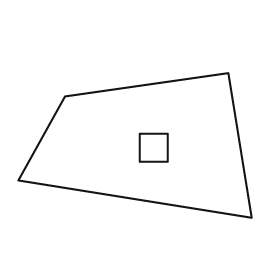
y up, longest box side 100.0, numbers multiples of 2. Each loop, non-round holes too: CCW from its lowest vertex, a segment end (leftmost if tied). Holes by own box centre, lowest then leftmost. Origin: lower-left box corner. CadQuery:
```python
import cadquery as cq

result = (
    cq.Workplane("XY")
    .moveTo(100.0, 0.0)
    .lineTo(90.0, 62.0)
    .lineTo(20.0, 52.0)
    .lineTo(0.0, 16.0)
    .close()
    .moveTo(52.0, 24.0)
    .lineTo(64.0, 24.0)
    .lineTo(64.0, 36.0)
    .lineTo(52.0, 36.0)
    .close()
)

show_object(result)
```